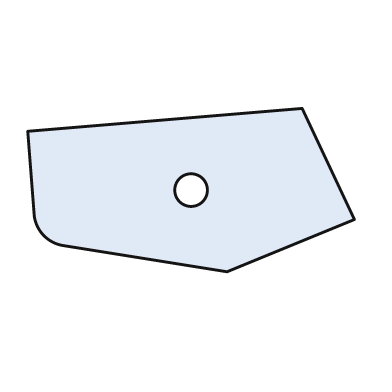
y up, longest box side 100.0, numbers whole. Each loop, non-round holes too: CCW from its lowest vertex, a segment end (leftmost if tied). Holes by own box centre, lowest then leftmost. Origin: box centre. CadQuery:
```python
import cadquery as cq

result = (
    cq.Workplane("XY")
    .moveTo(11.0, -25.0)
    .lineTo(50.0, -9.0)
    .lineTo(34.0, 25.0)
    .lineTo(-50.0, 18.0)
    .lineTo(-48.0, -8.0)
    .threePointArc((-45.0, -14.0), (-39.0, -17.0))
    .close()
    .moveTo(0.0, 0.0)
    .circle(5.0)
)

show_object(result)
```